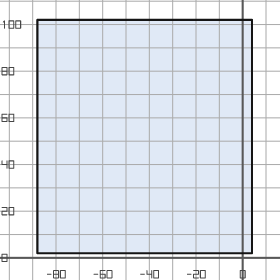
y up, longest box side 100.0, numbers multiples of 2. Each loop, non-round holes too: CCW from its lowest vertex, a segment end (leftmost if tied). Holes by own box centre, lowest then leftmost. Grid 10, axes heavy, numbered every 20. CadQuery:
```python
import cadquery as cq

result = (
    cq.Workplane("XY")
    .moveTo(-88.0, 2.0)
    .lineTo(4.0, 2.0)
    .lineTo(4.0, 102.0)
    .lineTo(-88.0, 102.0)
    .close()
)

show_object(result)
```